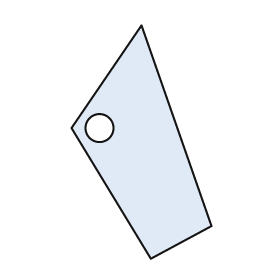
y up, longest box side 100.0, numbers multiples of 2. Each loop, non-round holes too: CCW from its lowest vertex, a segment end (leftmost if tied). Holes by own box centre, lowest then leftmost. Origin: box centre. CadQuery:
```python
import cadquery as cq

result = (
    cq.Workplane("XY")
    .moveTo(4.0, -50.0)
    .lineTo(30.0, -36.0)
    .lineTo(0.0, 50.0)
    .lineTo(-30.0, 6.0)
    .close()
    .moveTo(-18.0, 6.0)
    .circle(6.0)
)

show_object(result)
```